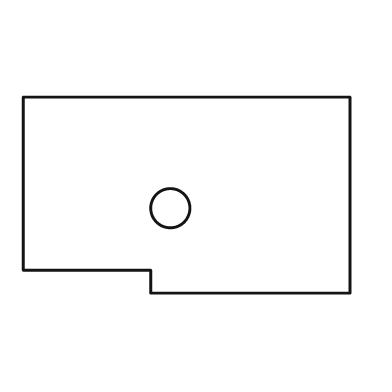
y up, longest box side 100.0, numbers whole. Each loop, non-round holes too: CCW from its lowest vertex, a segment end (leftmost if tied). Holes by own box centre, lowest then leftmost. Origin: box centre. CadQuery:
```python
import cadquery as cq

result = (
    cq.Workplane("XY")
    .moveTo(-11.0, -30.0)
    .lineTo(50.0, -30.0)
    .lineTo(50.0, 30.0)
    .lineTo(-50.0, 30.0)
    .lineTo(-50.0, -23.0)
    .lineTo(-11.0, -23.0)
    .close()
    .moveTo(-5.0, -4.0)
    .circle(6.0)
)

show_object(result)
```